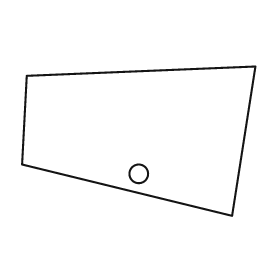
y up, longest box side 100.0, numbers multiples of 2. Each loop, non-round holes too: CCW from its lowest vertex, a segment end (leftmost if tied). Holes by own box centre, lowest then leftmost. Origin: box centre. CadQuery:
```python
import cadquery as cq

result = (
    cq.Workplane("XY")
    .moveTo(40.0, -32.0)
    .lineTo(50.0, 32.0)
    .lineTo(-48.0, 28.0)
    .lineTo(-50.0, -10.0)
    .close()
    .moveTo(0.0, -14.0)
    .circle(4.0)
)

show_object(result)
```